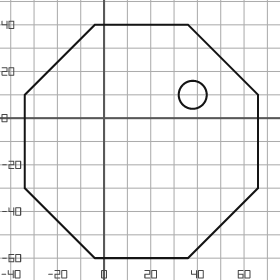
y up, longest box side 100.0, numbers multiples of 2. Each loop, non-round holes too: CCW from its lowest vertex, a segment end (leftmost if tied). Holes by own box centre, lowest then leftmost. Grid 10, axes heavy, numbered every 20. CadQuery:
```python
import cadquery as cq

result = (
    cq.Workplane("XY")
    .moveTo(-4.0, -60.0)
    .lineTo(36.0, -60.0)
    .lineTo(66.0, -30.0)
    .lineTo(66.0, 10.0)
    .lineTo(36.0, 40.0)
    .lineTo(-4.0, 40.0)
    .lineTo(-34.0, 10.0)
    .lineTo(-34.0, -30.0)
    .close()
    .moveTo(38.0, 10.0)
    .circle(6.0)
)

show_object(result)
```